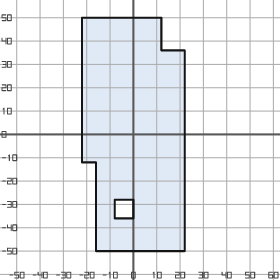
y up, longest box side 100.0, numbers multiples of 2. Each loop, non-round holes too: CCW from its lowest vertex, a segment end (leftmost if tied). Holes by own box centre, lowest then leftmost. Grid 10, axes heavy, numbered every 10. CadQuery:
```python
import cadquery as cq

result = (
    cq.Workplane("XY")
    .moveTo(-16.0, -50.0)
    .lineTo(22.0, -50.0)
    .lineTo(22.0, 36.0)
    .lineTo(12.0, 36.0)
    .lineTo(12.0, 50.0)
    .lineTo(-22.0, 50.0)
    .lineTo(-22.0, -12.0)
    .lineTo(-16.0, -12.0)
    .close()
    .moveTo(-8.0, -36.0)
    .lineTo(0.0, -36.0)
    .lineTo(0.0, -28.0)
    .lineTo(-8.0, -28.0)
    .close()
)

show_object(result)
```